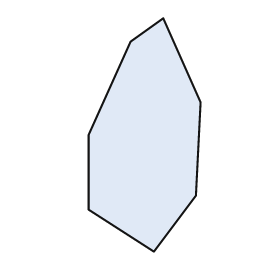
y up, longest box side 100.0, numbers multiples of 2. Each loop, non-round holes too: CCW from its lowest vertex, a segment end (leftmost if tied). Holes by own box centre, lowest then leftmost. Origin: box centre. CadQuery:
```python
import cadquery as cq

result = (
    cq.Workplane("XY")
    .moveTo(4.0, -50.0)
    .lineTo(22.0, -26.0)
    .lineTo(24.0, 14.0)
    .lineTo(8.0, 50.0)
    .lineTo(-6.0, 40.0)
    .lineTo(-24.0, 0.0)
    .lineTo(-24.0, -32.0)
    .close()
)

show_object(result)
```